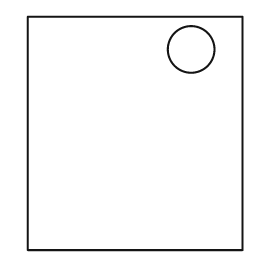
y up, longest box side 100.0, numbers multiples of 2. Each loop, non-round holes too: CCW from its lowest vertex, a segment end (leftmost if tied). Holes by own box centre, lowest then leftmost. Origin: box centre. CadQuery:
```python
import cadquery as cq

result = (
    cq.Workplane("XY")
    .moveTo(-46.0, -50.0)
    .lineTo(46.0, -50.0)
    .lineTo(46.0, 50.0)
    .lineTo(-46.0, 50.0)
    .close()
    .moveTo(24.0, 36.0)
    .circle(10.0)
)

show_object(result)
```